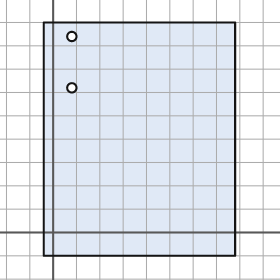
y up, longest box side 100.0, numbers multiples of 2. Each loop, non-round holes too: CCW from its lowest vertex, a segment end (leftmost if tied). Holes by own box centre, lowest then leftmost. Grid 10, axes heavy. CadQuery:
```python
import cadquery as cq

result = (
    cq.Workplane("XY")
    .moveTo(-4.0, -10.0)
    .lineTo(78.0, -10.0)
    .lineTo(78.0, 90.0)
    .lineTo(-4.0, 90.0)
    .close()
    .moveTo(8.0, 62.0)
    .circle(2.0)
    .moveTo(8.0, 84.0)
    .circle(2.0)
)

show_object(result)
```